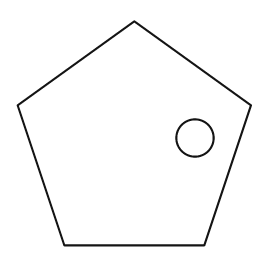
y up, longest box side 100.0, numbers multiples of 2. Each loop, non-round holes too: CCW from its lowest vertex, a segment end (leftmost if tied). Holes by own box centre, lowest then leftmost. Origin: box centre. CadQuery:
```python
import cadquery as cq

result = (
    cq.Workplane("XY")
    .moveTo(-30.0, -48.0)
    .lineTo(30.0, -48.0)
    .lineTo(50.0, 12.0)
    .lineTo(0.0, 48.0)
    .lineTo(-50.0, 12.0)
    .close()
    .moveTo(26.0, -2.0)
    .circle(8.0)
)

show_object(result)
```